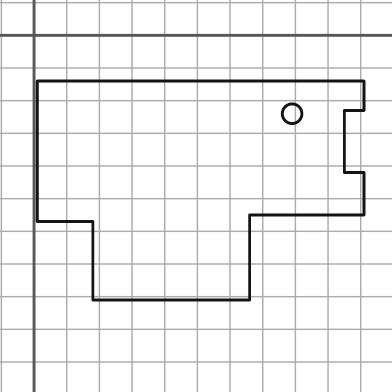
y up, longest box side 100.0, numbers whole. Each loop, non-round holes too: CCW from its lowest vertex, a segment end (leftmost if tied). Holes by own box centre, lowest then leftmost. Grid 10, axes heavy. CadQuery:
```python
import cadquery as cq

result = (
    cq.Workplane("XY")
    .moveTo(18.0, -81.0)
    .lineTo(66.0, -81.0)
    .lineTo(66.0, -55.0)
    .lineTo(101.0, -55.0)
    .lineTo(101.0, -42.0)
    .lineTo(95.0, -42.0)
    .lineTo(95.0, -23.0)
    .lineTo(101.0, -23.0)
    .lineTo(101.0, -14.0)
    .lineTo(1.0, -14.0)
    .lineTo(1.0, -57.0)
    .lineTo(18.0, -57.0)
    .close()
    .moveTo(79.0, -24.0)
    .circle(3.0)
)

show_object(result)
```